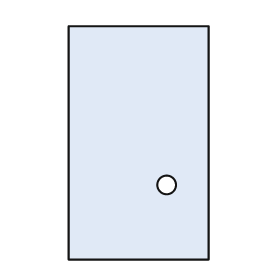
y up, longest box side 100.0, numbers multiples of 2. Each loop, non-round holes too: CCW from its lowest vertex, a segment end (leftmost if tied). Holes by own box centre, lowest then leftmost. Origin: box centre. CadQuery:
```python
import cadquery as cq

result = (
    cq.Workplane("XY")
    .moveTo(-30.0, -50.0)
    .lineTo(30.0, -50.0)
    .lineTo(30.0, 50.0)
    .lineTo(-30.0, 50.0)
    .close()
    .moveTo(12.0, -18.0)
    .circle(4.0)
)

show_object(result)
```